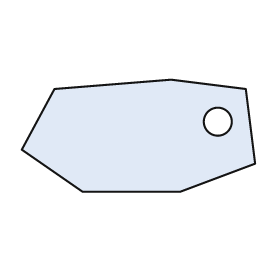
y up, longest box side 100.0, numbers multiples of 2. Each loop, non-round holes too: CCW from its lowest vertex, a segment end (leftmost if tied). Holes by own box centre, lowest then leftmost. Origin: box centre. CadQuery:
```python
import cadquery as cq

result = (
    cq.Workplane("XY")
    .moveTo(-24.0, -24.0)
    .lineTo(18.0, -24.0)
    .lineTo(50.0, -12.0)
    .lineTo(46.0, 20.0)
    .lineTo(14.0, 24.0)
    .lineTo(-36.0, 20.0)
    .lineTo(-50.0, -6.0)
    .close()
    .moveTo(34.0, 6.0)
    .circle(6.0)
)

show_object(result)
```